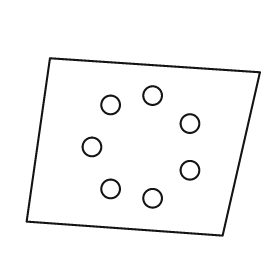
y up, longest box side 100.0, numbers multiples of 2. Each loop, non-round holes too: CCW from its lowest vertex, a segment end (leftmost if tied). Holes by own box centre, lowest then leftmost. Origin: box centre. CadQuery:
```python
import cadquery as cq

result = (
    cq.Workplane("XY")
    .moveTo(34.0, -38.0)
    .lineTo(50.0, 32.0)
    .lineTo(-40.0, 38.0)
    .lineTo(-50.0, -32.0)
    .close()
    .moveTo(4.0, -22.0)
    .circle(4.0)
    .moveTo(-14.0, -18.0)
    .circle(4.0)
    .moveTo(20.0, -10.0)
    .circle(4.0)
    .moveTo(-22.0, 0.0)
    .circle(4.0)
    .moveTo(20.0, 10.0)
    .circle(4.0)
    .moveTo(-14.0, 18.0)
    .circle(4.0)
    .moveTo(4.0, 22.0)
    .circle(4.0)
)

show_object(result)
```